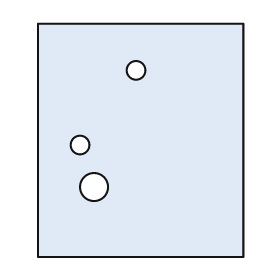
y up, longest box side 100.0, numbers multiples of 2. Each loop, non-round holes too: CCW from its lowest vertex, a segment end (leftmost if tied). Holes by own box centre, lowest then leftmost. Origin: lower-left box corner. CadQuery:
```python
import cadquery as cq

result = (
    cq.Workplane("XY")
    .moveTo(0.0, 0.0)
    .lineTo(88.0, 0.0)
    .lineTo(88.0, 100.0)
    .lineTo(0.0, 100.0)
    .close()
    .moveTo(24.0, 30.0)
    .circle(6.0)
    .moveTo(18.0, 48.0)
    .circle(4.0)
    .moveTo(42.0, 80.0)
    .circle(4.0)
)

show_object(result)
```